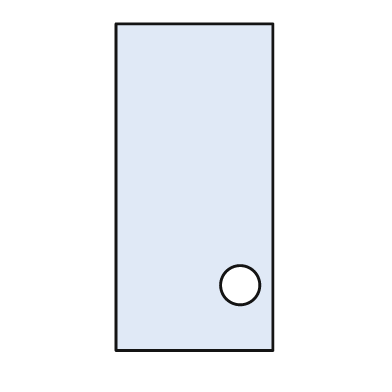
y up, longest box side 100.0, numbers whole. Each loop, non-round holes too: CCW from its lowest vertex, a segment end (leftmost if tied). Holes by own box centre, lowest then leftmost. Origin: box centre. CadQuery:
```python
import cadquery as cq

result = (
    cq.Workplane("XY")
    .moveTo(-24.0, -50.0)
    .lineTo(24.0, -50.0)
    .lineTo(24.0, 50.0)
    .lineTo(-24.0, 50.0)
    .close()
    .moveTo(14.0, -30.0)
    .circle(6.0)
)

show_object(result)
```